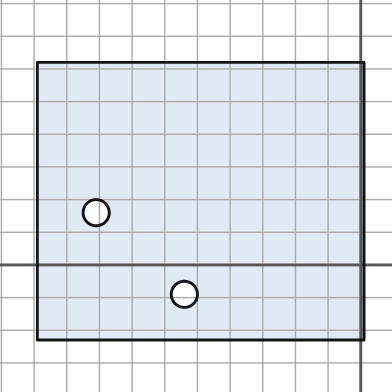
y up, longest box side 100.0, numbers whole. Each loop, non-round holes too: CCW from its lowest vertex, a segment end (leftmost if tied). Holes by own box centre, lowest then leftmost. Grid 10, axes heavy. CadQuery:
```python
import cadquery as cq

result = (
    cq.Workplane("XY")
    .moveTo(-99.0, -23.0)
    .lineTo(1.0, -23.0)
    .lineTo(1.0, 62.0)
    .lineTo(-99.0, 62.0)
    .close()
    .moveTo(-54.0, -9.0)
    .circle(4.0)
    .moveTo(-81.0, 16.0)
    .circle(4.0)
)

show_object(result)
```